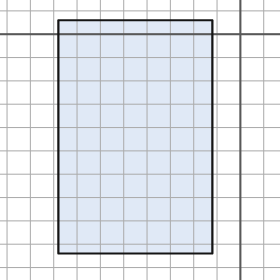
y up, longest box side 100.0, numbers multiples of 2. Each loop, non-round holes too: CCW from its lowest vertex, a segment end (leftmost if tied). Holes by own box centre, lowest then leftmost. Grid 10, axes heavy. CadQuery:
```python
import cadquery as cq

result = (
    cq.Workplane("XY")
    .moveTo(-78.0, -94.0)
    .lineTo(-12.0, -94.0)
    .lineTo(-12.0, 6.0)
    .lineTo(-78.0, 6.0)
    .close()
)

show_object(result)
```